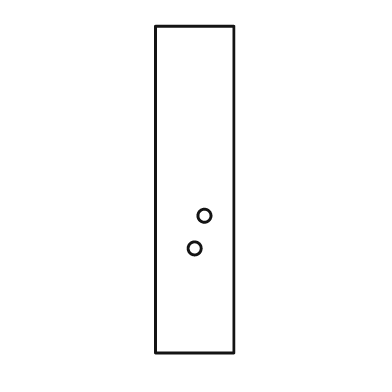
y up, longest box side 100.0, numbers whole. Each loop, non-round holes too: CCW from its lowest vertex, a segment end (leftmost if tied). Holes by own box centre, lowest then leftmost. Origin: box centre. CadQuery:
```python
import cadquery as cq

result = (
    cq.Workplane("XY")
    .moveTo(-12.0, -50.0)
    .lineTo(12.0, -50.0)
    .lineTo(12.0, 50.0)
    .lineTo(-12.0, 50.0)
    .close()
    .moveTo(0.0, -18.0)
    .circle(2.0)
    .moveTo(3.0, -8.0)
    .circle(2.0)
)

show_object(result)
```